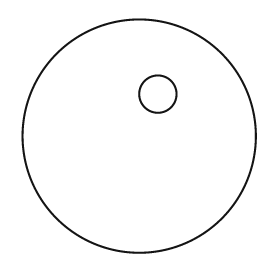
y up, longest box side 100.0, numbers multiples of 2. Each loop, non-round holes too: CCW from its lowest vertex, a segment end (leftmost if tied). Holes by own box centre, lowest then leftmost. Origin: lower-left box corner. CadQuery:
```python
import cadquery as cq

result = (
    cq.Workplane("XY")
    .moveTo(50.0, 50.0)
    .circle(50.0)
    .moveTo(58.0, 68.0)
    .circle(8.0)
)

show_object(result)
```